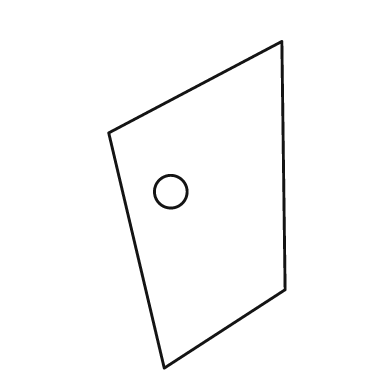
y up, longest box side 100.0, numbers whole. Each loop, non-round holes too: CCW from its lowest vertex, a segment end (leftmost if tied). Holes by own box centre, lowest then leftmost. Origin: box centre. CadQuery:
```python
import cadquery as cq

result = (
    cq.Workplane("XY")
    .moveTo(-10.0, -50.0)
    .lineTo(27.0, -26.0)
    .lineTo(26.0, 50.0)
    .lineTo(-27.0, 22.0)
    .close()
    .moveTo(-8.0, 4.0)
    .circle(5.0)
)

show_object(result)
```